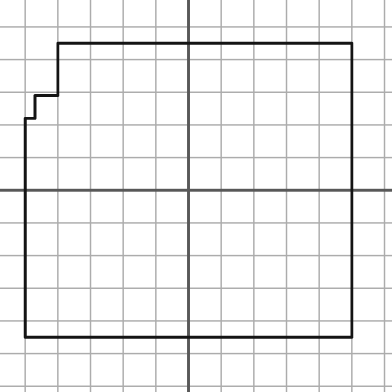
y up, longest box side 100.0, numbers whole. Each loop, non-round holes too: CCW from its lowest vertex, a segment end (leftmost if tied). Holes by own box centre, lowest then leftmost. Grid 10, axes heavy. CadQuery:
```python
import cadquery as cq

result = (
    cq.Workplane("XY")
    .moveTo(-50.0, -45.0)
    .lineTo(50.0, -45.0)
    .lineTo(50.0, 45.0)
    .lineTo(-40.0, 45.0)
    .lineTo(-40.0, 29.0)
    .lineTo(-47.0, 29.0)
    .lineTo(-47.0, 22.0)
    .lineTo(-50.0, 22.0)
    .close()
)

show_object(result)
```